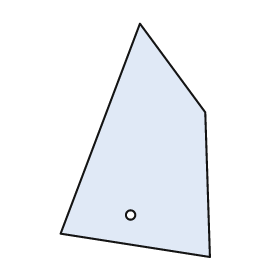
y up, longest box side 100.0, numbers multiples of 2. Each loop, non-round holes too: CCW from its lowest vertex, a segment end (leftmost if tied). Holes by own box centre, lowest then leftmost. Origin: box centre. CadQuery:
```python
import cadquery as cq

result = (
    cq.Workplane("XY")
    .moveTo(32.0, -50.0)
    .lineTo(30.0, 12.0)
    .lineTo(2.0, 50.0)
    .lineTo(-32.0, -40.0)
    .close()
    .moveTo(-2.0, -32.0)
    .circle(2.0)
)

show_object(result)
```